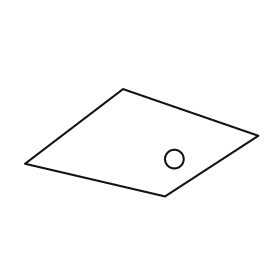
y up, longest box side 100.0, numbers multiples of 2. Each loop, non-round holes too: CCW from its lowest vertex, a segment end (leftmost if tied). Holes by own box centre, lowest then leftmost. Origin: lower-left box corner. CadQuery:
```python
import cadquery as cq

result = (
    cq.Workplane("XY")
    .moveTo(60.0, 0.0)
    .lineTo(100.0, 26.0)
    .lineTo(42.0, 46.0)
    .lineTo(0.0, 14.0)
    .close()
    .moveTo(64.0, 16.0)
    .circle(4.0)
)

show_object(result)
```